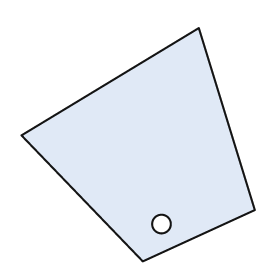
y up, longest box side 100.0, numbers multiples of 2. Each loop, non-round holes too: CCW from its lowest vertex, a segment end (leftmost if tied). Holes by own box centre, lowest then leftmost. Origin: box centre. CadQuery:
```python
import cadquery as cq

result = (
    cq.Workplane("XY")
    .moveTo(2.0, -50.0)
    .lineTo(50.0, -28.0)
    .lineTo(26.0, 50.0)
    .lineTo(-50.0, 4.0)
    .close()
    .moveTo(10.0, -34.0)
    .circle(4.0)
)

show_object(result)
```